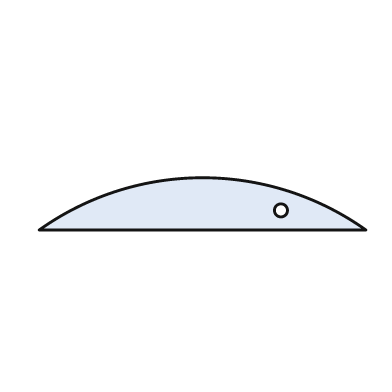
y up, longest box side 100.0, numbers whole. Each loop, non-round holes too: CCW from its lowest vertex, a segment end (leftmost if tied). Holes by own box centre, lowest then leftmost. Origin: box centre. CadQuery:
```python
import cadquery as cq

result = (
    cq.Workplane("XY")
    .moveTo(-50.0, -8.0)
    .lineTo(50.0, -8.0)
    .threePointArc((0.0, 8.0), (-50.0, -8.0))
    .close()
    .moveTo(24.0, -2.0)
    .circle(2.0)
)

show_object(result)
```